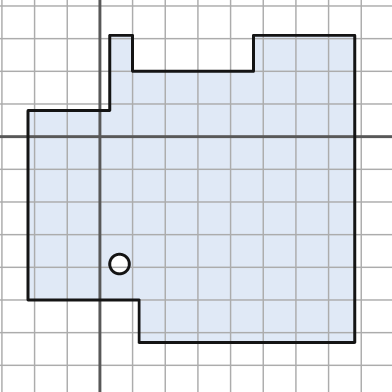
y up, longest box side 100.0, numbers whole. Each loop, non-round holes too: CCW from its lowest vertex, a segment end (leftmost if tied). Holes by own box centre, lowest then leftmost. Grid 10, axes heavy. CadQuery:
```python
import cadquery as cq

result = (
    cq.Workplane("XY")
    .moveTo(12.0, -63.0)
    .lineTo(78.0, -63.0)
    .lineTo(78.0, 31.0)
    .lineTo(47.0, 31.0)
    .lineTo(47.0, 20.0)
    .lineTo(10.0, 20.0)
    .lineTo(10.0, 31.0)
    .lineTo(3.0, 31.0)
    .lineTo(3.0, 8.0)
    .lineTo(-22.0, 8.0)
    .lineTo(-22.0, -50.0)
    .lineTo(12.0, -50.0)
    .close()
    .moveTo(6.0, -39.0)
    .circle(3.0)
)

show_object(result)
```